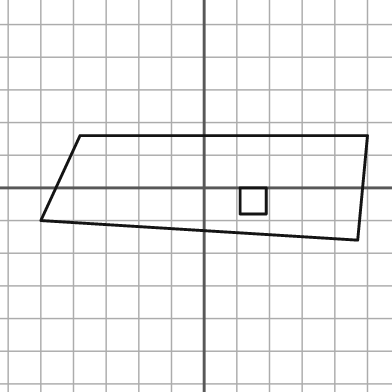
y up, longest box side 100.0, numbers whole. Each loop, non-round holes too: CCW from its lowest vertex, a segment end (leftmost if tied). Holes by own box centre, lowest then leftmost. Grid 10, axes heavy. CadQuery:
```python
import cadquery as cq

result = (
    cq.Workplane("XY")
    .moveTo(47.0, -16.0)
    .lineTo(50.0, 16.0)
    .lineTo(-38.0, 16.0)
    .lineTo(-50.0, -10.0)
    .close()
    .moveTo(11.0, -8.0)
    .lineTo(19.0, -8.0)
    .lineTo(19.0, 0.0)
    .lineTo(11.0, 0.0)
    .close()
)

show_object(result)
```